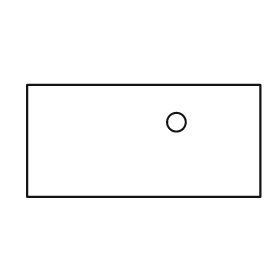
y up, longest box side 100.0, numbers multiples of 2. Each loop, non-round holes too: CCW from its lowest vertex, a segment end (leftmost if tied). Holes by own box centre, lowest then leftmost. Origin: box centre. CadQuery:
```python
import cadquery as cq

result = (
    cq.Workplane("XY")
    .moveTo(-50.0, -24.0)
    .lineTo(50.0, -24.0)
    .lineTo(50.0, 24.0)
    .lineTo(-50.0, 24.0)
    .close()
    .moveTo(14.0, 8.0)
    .circle(4.0)
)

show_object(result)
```